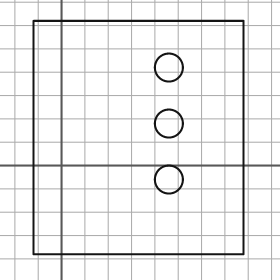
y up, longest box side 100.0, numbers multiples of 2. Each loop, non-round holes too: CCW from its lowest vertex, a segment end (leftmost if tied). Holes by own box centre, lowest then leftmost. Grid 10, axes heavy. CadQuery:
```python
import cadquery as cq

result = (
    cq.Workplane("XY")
    .moveTo(-12.0, -38.0)
    .lineTo(78.0, -38.0)
    .lineTo(78.0, 62.0)
    .lineTo(-12.0, 62.0)
    .close()
    .moveTo(46.0, -6.0)
    .circle(6.0)
    .moveTo(46.0, 18.0)
    .circle(6.0)
    .moveTo(46.0, 42.0)
    .circle(6.0)
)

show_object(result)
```